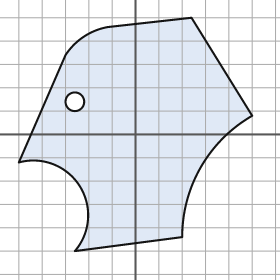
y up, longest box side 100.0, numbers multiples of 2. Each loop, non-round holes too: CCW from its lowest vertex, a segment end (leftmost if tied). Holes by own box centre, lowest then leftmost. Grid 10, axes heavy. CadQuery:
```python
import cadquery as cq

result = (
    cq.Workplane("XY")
    .moveTo(-26.0, -50.0)
    .lineTo(20.0, -44.0)
    .threePointArc((28.0, -14.0), (50.0, 8.0))
    .lineTo(24.0, 50.0)
    .lineTo(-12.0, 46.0)
    .threePointArc((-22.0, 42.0), (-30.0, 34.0))
    .lineTo(-50.0, -12.0)
    .threePointArc((-24.0, -22.0), (-26.0, -50.0))
    .close()
    .moveTo(-26.0, 14.0)
    .circle(4.0)
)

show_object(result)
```